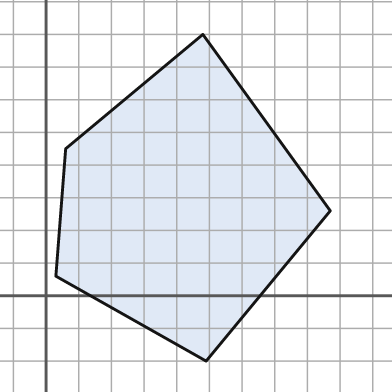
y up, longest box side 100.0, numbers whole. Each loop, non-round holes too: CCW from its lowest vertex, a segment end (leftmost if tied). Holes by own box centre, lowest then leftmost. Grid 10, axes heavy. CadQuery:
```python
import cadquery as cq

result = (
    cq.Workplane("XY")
    .moveTo(49.0, -20.0)
    .lineTo(87.0, 26.0)
    .lineTo(48.0, 80.0)
    .lineTo(6.0, 45.0)
    .lineTo(3.0, 6.0)
    .close()
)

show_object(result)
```